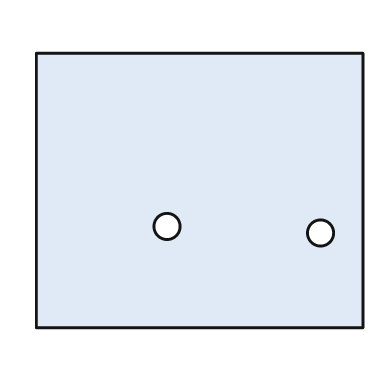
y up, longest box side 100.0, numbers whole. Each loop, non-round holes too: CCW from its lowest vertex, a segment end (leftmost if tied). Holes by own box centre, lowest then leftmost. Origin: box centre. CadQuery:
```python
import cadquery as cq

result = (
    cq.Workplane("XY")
    .moveTo(-50.0, -42.0)
    .lineTo(50.0, -42.0)
    .lineTo(50.0, 42.0)
    .lineTo(-50.0, 42.0)
    .close()
    .moveTo(37.0, -13.0)
    .circle(4.0)
    .moveTo(-10.0, -11.0)
    .circle(4.0)
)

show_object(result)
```